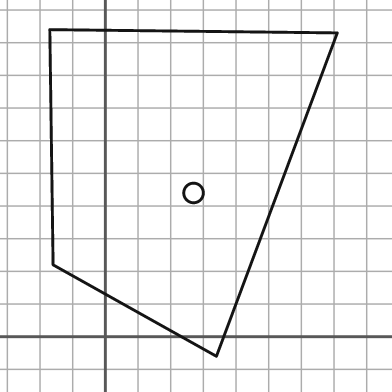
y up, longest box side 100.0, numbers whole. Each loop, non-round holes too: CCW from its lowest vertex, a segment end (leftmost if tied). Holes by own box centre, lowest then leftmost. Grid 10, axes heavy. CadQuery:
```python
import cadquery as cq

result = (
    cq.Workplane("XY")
    .moveTo(34.0, -6.0)
    .lineTo(71.0, 93.0)
    .lineTo(-17.0, 94.0)
    .lineTo(-16.0, 22.0)
    .close()
    .moveTo(27.0, 44.0)
    .circle(3.0)
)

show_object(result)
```